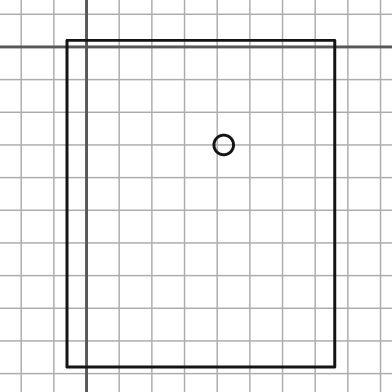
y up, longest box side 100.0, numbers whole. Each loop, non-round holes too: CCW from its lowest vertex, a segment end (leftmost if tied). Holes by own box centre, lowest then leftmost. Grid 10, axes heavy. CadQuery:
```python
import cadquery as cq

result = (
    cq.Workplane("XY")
    .moveTo(-6.0, -98.0)
    .lineTo(76.0, -98.0)
    .lineTo(76.0, 2.0)
    .lineTo(-6.0, 2.0)
    .close()
    .moveTo(42.0, -30.0)
    .circle(3.0)
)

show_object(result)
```